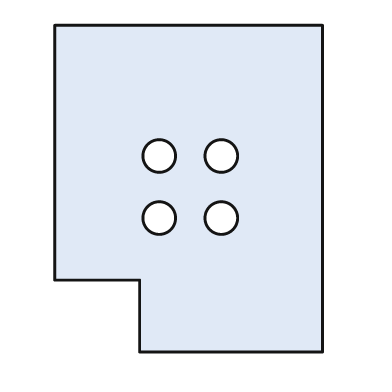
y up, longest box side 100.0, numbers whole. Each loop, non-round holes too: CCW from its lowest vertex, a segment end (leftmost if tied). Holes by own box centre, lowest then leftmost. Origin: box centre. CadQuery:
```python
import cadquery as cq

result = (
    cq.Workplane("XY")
    .moveTo(-15.0, -50.0)
    .lineTo(41.0, -50.0)
    .lineTo(41.0, 50.0)
    .lineTo(-41.0, 50.0)
    .lineTo(-41.0, -28.0)
    .lineTo(-15.0, -28.0)
    .close()
    .moveTo(-9.0, -9.0)
    .circle(5.0)
    .moveTo(10.0, -9.0)
    .circle(5.0)
    .moveTo(-9.0, 10.0)
    .circle(5.0)
    .moveTo(10.0, 10.0)
    .circle(5.0)
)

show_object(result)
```